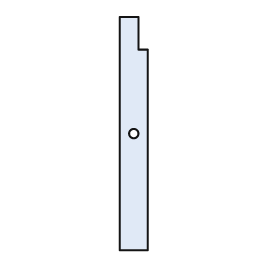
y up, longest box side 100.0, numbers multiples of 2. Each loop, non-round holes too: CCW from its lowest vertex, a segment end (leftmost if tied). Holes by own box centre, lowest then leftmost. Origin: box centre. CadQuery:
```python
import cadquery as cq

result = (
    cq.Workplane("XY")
    .moveTo(-6.0, -50.0)
    .lineTo(6.0, -50.0)
    .lineTo(6.0, 36.0)
    .lineTo(2.0, 36.0)
    .lineTo(2.0, 50.0)
    .lineTo(-6.0, 50.0)
    .close()
    .moveTo(0.0, 0.0)
    .circle(2.0)
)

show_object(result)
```